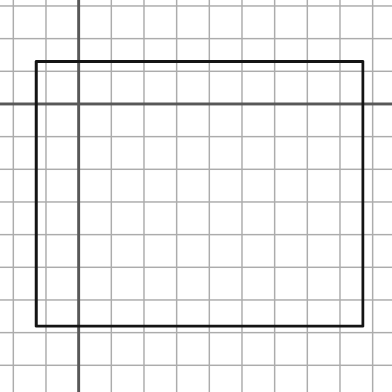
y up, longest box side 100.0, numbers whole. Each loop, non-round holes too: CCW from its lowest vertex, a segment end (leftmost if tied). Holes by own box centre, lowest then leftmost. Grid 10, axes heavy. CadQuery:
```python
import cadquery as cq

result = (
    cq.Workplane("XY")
    .moveTo(-13.0, -68.0)
    .lineTo(87.0, -68.0)
    .lineTo(87.0, 13.0)
    .lineTo(-13.0, 13.0)
    .close()
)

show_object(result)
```